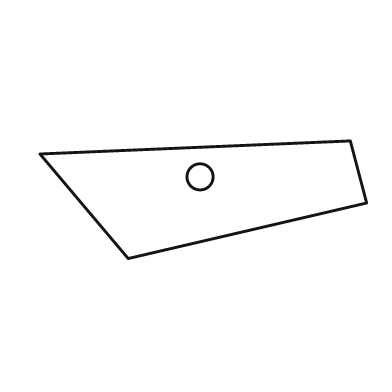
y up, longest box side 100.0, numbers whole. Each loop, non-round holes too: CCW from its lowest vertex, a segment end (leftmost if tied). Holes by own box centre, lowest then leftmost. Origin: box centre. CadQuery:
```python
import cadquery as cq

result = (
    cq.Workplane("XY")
    .moveTo(-23.0, -18.0)
    .lineTo(50.0, -1.0)
    .lineTo(45.0, 18.0)
    .lineTo(-50.0, 14.0)
    .close()
    .moveTo(-1.0, 7.0)
    .circle(4.0)
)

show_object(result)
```